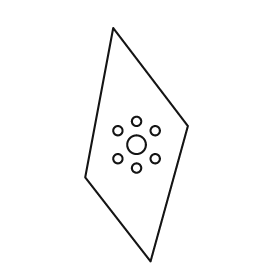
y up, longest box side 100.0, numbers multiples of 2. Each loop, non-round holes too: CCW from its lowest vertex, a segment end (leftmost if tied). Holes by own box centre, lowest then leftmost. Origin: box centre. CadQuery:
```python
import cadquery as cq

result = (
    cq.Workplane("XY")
    .moveTo(6.0, -50.0)
    .lineTo(22.0, 8.0)
    .lineTo(-10.0, 50.0)
    .lineTo(-22.0, -14.0)
    .close()
    .moveTo(0.0, -10.0)
    .circle(2.0)
    .moveTo(-8.0, -6.0)
    .circle(2.0)
    .moveTo(8.0, -6.0)
    .circle(2.0)
    .moveTo(0.0, 0.0)
    .circle(4.0)
    .moveTo(-8.0, 6.0)
    .circle(2.0)
    .moveTo(8.0, 6.0)
    .circle(2.0)
    .moveTo(0.0, 10.0)
    .circle(2.0)
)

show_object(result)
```